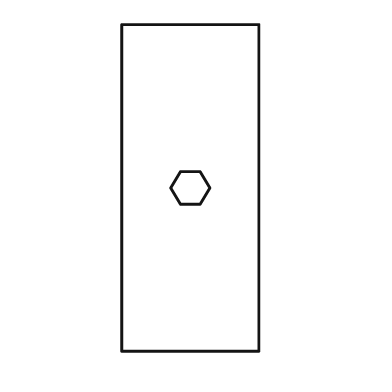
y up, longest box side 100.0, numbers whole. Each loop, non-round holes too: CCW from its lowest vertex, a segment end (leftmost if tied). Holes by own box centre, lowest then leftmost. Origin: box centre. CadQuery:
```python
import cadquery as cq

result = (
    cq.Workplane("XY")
    .moveTo(-21.0, -50.0)
    .lineTo(21.0, -50.0)
    .lineTo(21.0, 50.0)
    .lineTo(-21.0, 50.0)
    .close()
    .moveTo(-3.0, -5.0)
    .lineTo(3.0, -5.0)
    .lineTo(6.0, 0.0)
    .lineTo(3.0, 5.0)
    .lineTo(-3.0, 5.0)
    .lineTo(-6.0, 0.0)
    .close()
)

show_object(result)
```